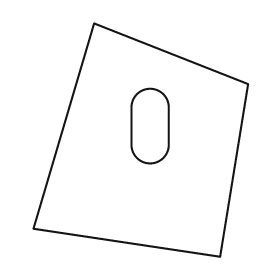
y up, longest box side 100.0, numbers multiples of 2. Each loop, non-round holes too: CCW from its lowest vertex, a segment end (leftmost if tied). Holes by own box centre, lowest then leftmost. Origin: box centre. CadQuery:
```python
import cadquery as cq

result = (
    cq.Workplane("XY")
    .moveTo(34.0, -50.0)
    .lineTo(46.0, 24.0)
    .lineTo(-20.0, 50.0)
    .lineTo(-46.0, -38.0)
    .close()
    .moveTo(-4.0, -2.0)
    .threePointArc((4.0, -10.0), (12.0, -2.0))
    .lineTo(12.0, 14.0)
    .threePointArc((4.0, 22.0), (-4.0, 14.0))
    .close()
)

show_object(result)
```